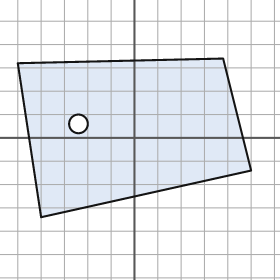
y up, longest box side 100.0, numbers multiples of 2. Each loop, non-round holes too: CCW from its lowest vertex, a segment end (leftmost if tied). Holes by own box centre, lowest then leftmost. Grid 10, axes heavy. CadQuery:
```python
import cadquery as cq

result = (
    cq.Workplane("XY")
    .moveTo(-40.0, -34.0)
    .lineTo(50.0, -14.0)
    .lineTo(38.0, 34.0)
    .lineTo(-50.0, 32.0)
    .close()
    .moveTo(-24.0, 6.0)
    .circle(4.0)
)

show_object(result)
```